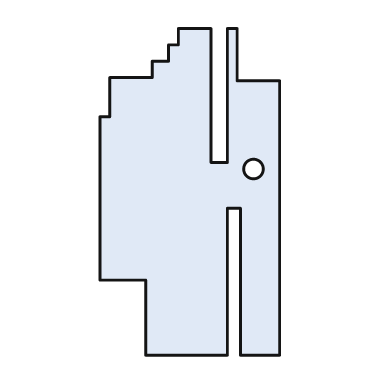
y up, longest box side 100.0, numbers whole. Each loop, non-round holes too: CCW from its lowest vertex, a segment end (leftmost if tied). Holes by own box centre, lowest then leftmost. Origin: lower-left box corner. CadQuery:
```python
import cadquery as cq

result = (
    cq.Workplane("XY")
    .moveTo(14.0, 0.0)
    .lineTo(39.0, 0.0)
    .lineTo(39.0, 45.0)
    .lineTo(43.0, 45.0)
    .lineTo(43.0, 0.0)
    .lineTo(55.0, 0.0)
    .lineTo(55.0, 84.0)
    .lineTo(42.0, 84.0)
    .lineTo(42.0, 100.0)
    .lineTo(39.0, 100.0)
    .lineTo(39.0, 59.0)
    .lineTo(34.0, 59.0)
    .lineTo(34.0, 100.0)
    .lineTo(24.0, 100.0)
    .lineTo(24.0, 95.0)
    .lineTo(21.0, 95.0)
    .lineTo(21.0, 90.0)
    .lineTo(16.0, 90.0)
    .lineTo(16.0, 85.0)
    .lineTo(3.0, 85.0)
    .lineTo(3.0, 73.0)
    .lineTo(0.0, 73.0)
    .lineTo(0.0, 23.0)
    .lineTo(14.0, 23.0)
    .close()
    .moveTo(47.0, 57.0)
    .circle(3.0)
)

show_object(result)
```